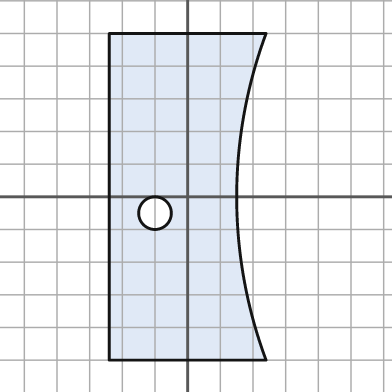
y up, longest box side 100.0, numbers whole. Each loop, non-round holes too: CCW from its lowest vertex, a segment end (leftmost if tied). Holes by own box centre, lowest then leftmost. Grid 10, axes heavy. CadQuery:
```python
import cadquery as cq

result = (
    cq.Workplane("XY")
    .moveTo(-24.0, -50.0)
    .lineTo(24.0, -50.0)
    .threePointArc((15.0, 0.0), (24.0, 50.0))
    .lineTo(-24.0, 50.0)
    .close()
    .moveTo(-10.0, -5.0)
    .circle(5.0)
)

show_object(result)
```